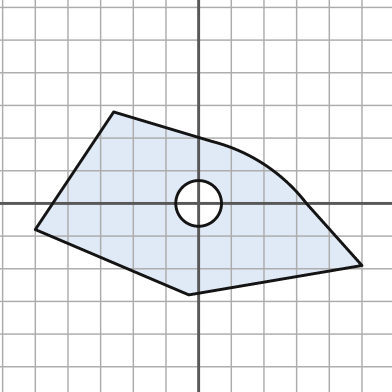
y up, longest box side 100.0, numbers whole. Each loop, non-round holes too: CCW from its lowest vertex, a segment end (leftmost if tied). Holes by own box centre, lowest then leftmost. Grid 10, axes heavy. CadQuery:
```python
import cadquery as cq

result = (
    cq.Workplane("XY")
    .moveTo(-3.0, -28.0)
    .lineTo(50.0, -19.0)
    .lineTo(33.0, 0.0)
    .threePointArc((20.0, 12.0), (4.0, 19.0))
    .lineTo(-26.0, 28.0)
    .lineTo(-50.0, -8.0)
    .close()
    .moveTo(0.0, 0.0)
    .circle(7.0)
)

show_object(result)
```